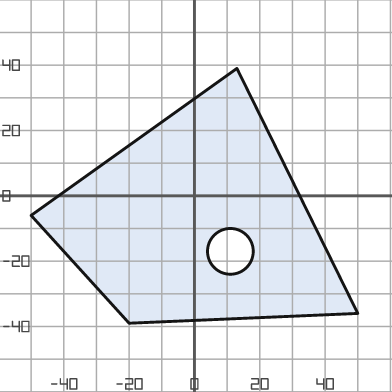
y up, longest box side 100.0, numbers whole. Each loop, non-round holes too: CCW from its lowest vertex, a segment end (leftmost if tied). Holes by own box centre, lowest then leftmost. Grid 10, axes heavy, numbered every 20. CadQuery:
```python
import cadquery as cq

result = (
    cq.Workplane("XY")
    .moveTo(-20.0, -39.0)
    .lineTo(50.0, -36.0)
    .lineTo(13.0, 39.0)
    .lineTo(-50.0, -6.0)
    .close()
    .moveTo(11.0, -17.0)
    .circle(7.0)
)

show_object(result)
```